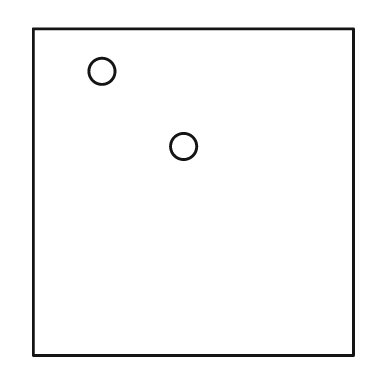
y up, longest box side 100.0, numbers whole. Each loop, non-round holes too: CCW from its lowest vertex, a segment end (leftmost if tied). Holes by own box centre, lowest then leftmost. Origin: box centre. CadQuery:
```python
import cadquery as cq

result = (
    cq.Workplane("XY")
    .moveTo(-49.0, -50.0)
    .lineTo(49.0, -50.0)
    .lineTo(49.0, 50.0)
    .lineTo(-49.0, 50.0)
    .close()
    .moveTo(-3.0, 14.0)
    .circle(4.0)
    .moveTo(-28.0, 37.0)
    .circle(4.0)
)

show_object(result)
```